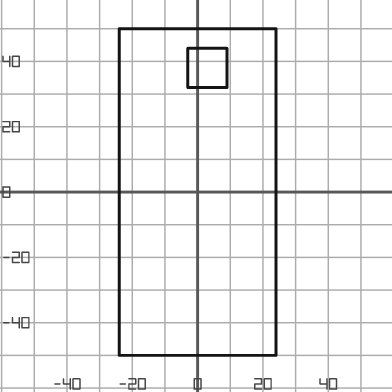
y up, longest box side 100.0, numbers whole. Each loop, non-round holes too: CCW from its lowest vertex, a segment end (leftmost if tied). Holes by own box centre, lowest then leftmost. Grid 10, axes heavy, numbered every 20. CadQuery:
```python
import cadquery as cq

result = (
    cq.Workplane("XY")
    .moveTo(-24.0, -50.0)
    .lineTo(24.0, -50.0)
    .lineTo(24.0, 50.0)
    .lineTo(-24.0, 50.0)
    .close()
    .moveTo(-3.0, 32.0)
    .lineTo(9.0, 32.0)
    .lineTo(9.0, 44.0)
    .lineTo(-3.0, 44.0)
    .close()
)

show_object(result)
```